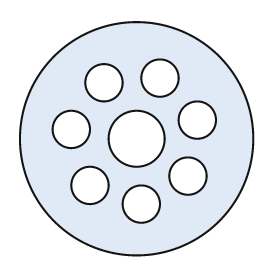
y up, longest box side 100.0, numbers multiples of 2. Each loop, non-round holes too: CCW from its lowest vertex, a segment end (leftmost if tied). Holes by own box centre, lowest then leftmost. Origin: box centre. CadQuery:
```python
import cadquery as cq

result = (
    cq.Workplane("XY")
    .moveTo(0.0, 0.0)
    .circle(50.0)
    .moveTo(2.0, -28.0)
    .circle(8.0)
    .moveTo(-20.0, -20.0)
    .circle(8.0)
    .moveTo(22.0, -16.0)
    .circle(8.0)
    .moveTo(0.0, 0.0)
    .circle(12.0)
    .moveTo(-28.0, 4.0)
    .circle(8.0)
    .moveTo(26.0, 8.0)
    .circle(8.0)
    .moveTo(-14.0, 24.0)
    .circle(8.0)
    .moveTo(10.0, 26.0)
    .circle(8.0)
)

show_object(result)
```